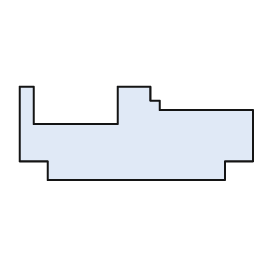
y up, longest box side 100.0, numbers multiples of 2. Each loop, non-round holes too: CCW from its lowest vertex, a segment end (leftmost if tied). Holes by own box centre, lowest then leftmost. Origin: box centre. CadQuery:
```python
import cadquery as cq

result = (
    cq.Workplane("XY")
    .moveTo(-38.0, -20.0)
    .lineTo(38.0, -20.0)
    .lineTo(38.0, -12.0)
    .lineTo(50.0, -12.0)
    .lineTo(50.0, 10.0)
    .lineTo(10.0, 10.0)
    .lineTo(10.0, 14.0)
    .lineTo(6.0, 14.0)
    .lineTo(6.0, 20.0)
    .lineTo(-8.0, 20.0)
    .lineTo(-8.0, 4.0)
    .lineTo(-44.0, 4.0)
    .lineTo(-44.0, 20.0)
    .lineTo(-50.0, 20.0)
    .lineTo(-50.0, -12.0)
    .lineTo(-38.0, -12.0)
    .close()
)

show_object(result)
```